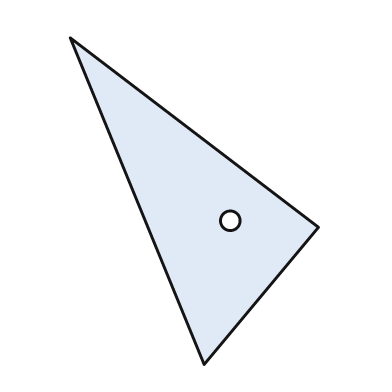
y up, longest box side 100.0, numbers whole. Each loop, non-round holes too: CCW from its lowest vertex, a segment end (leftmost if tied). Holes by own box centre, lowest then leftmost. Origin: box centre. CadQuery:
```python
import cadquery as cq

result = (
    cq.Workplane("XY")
    .moveTo(3.0, -50.0)
    .lineTo(38.0, -8.0)
    .lineTo(-38.0, 50.0)
    .close()
    .moveTo(11.0, -6.0)
    .circle(3.0)
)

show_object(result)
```